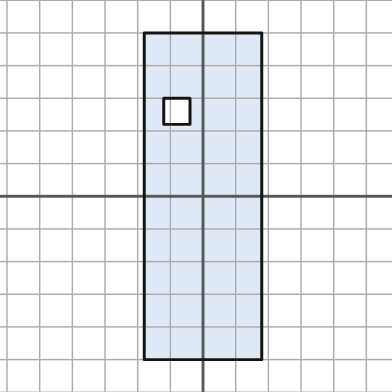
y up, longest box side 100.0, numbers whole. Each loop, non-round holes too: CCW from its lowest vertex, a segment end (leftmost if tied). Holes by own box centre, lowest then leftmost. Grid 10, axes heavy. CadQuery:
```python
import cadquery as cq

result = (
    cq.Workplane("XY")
    .moveTo(-18.0, -50.0)
    .lineTo(18.0, -50.0)
    .lineTo(18.0, 50.0)
    .lineTo(-18.0, 50.0)
    .close()
    .moveTo(-12.0, 22.0)
    .lineTo(-4.0, 22.0)
    .lineTo(-4.0, 30.0)
    .lineTo(-12.0, 30.0)
    .close()
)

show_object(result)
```